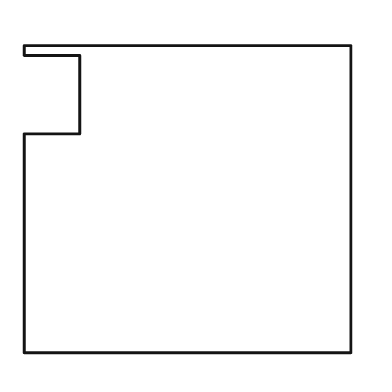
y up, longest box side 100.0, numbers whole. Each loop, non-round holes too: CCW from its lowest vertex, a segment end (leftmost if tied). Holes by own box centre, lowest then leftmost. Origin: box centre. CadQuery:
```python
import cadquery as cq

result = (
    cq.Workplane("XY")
    .moveTo(-50.0, -47.0)
    .lineTo(50.0, -47.0)
    .lineTo(50.0, 47.0)
    .lineTo(-50.0, 47.0)
    .lineTo(-50.0, 44.0)
    .lineTo(-33.0, 44.0)
    .lineTo(-33.0, 20.0)
    .lineTo(-50.0, 20.0)
    .close()
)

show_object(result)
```